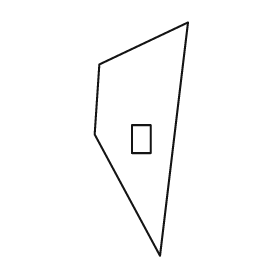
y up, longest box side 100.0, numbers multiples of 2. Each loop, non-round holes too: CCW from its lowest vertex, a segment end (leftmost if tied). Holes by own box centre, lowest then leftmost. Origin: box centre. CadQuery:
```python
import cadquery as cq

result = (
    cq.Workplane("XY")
    .moveTo(8.0, -50.0)
    .lineTo(20.0, 50.0)
    .lineTo(-18.0, 32.0)
    .lineTo(-20.0, 2.0)
    .close()
    .moveTo(-4.0, -6.0)
    .lineTo(4.0, -6.0)
    .lineTo(4.0, 6.0)
    .lineTo(-4.0, 6.0)
    .close()
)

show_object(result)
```